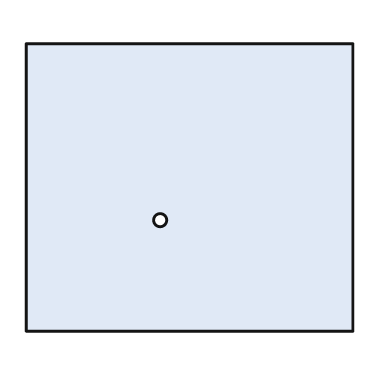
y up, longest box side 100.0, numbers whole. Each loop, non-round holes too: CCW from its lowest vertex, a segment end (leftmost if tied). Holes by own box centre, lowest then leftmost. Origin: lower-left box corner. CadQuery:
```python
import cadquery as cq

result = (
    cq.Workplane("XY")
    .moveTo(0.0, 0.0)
    .lineTo(100.0, 0.0)
    .lineTo(100.0, 88.0)
    .lineTo(0.0, 88.0)
    .close()
    .moveTo(41.0, 34.0)
    .circle(2.0)
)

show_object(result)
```